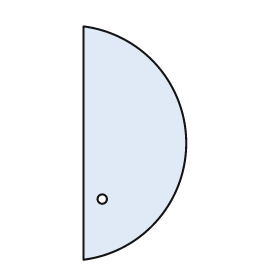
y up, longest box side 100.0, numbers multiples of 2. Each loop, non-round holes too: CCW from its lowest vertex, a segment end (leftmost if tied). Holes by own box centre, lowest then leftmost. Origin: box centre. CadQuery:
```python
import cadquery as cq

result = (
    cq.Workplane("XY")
    .moveTo(-22.0, -50.0)
    .threePointArc((22.0, 0.0), (-22.0, 50.0))
    .close()
    .moveTo(-14.0, -24.0)
    .circle(2.0)
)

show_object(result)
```